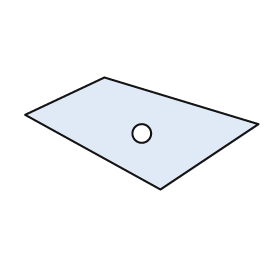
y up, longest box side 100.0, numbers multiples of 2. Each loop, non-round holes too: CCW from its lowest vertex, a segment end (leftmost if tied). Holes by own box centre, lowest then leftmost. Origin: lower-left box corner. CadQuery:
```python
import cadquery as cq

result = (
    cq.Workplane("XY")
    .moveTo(58.0, 0.0)
    .lineTo(100.0, 28.0)
    .lineTo(34.0, 48.0)
    .lineTo(0.0, 32.0)
    .close()
    .moveTo(50.0, 24.0)
    .circle(4.0)
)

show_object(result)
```